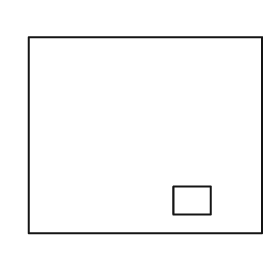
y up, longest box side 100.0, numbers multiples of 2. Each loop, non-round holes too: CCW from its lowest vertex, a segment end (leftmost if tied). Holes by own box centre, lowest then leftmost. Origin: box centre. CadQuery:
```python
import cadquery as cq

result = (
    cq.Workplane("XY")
    .moveTo(-50.0, -42.0)
    .lineTo(50.0, -42.0)
    .lineTo(50.0, 42.0)
    .lineTo(-50.0, 42.0)
    .close()
    .moveTo(12.0, -34.0)
    .lineTo(28.0, -34.0)
    .lineTo(28.0, -22.0)
    .lineTo(12.0, -22.0)
    .close()
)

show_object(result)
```